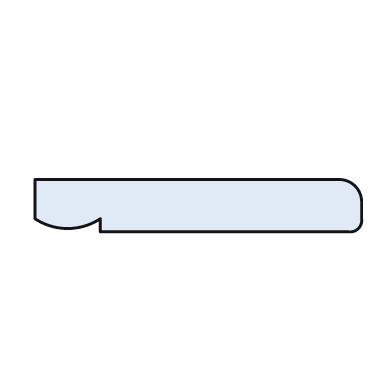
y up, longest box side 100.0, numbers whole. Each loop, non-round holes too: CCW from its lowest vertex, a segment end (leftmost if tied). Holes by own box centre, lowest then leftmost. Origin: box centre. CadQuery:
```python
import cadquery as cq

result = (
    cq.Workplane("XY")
    .moveTo(-30.0, -8.0)
    .lineTo(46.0, -8.0)
    .threePointArc((49.0, -7.0), (50.0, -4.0))
    .lineTo(50.0, 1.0)
    .threePointArc((48.0, 6.0), (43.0, 8.0))
    .lineTo(-50.0, 8.0)
    .lineTo(-50.0, -4.0)
    .threePointArc((-40.0, -7.0), (-30.0, -4.0))
    .close()
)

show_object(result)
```